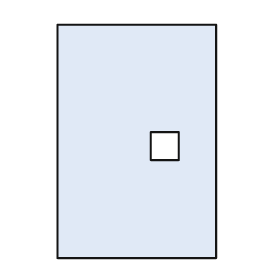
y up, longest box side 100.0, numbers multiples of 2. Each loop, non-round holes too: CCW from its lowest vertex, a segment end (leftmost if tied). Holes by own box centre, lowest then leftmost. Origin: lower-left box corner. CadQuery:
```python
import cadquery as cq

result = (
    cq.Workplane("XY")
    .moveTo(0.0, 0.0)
    .lineTo(68.0, 0.0)
    .lineTo(68.0, 100.0)
    .lineTo(0.0, 100.0)
    .close()
    .moveTo(40.0, 42.0)
    .lineTo(52.0, 42.0)
    .lineTo(52.0, 54.0)
    .lineTo(40.0, 54.0)
    .close()
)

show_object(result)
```